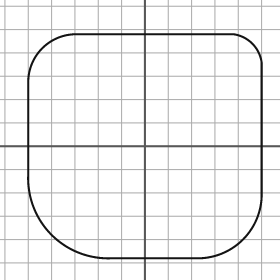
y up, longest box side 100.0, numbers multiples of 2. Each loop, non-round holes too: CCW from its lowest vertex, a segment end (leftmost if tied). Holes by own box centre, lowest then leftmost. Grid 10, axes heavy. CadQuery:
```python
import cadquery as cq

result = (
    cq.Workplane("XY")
    .moveTo(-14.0, -48.0)
    .lineTo(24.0, -48.0)
    .threePointArc((42.0, -40.0), (50.0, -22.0))
    .lineTo(50.0, 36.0)
    .threePointArc((46.0, 44.0), (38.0, 48.0))
    .lineTo(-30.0, 48.0)
    .threePointArc((-44.0, 42.0), (-50.0, 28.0))
    .lineTo(-50.0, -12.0)
    .threePointArc((-40.0, -38.0), (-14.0, -48.0))
    .close()
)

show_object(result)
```